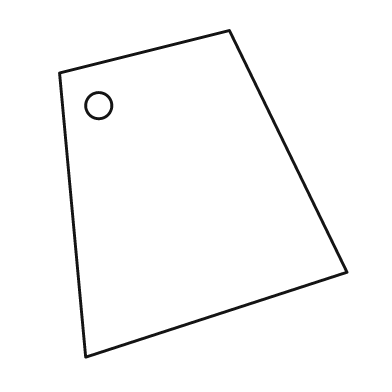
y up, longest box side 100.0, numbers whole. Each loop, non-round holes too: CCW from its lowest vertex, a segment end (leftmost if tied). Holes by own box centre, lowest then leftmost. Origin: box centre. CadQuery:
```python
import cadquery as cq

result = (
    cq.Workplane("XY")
    .moveTo(-36.0, -50.0)
    .lineTo(44.0, -24.0)
    .lineTo(8.0, 50.0)
    .lineTo(-44.0, 37.0)
    .close()
    .moveTo(-32.0, 27.0)
    .circle(4.0)
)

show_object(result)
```